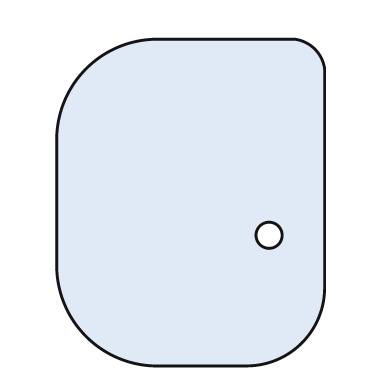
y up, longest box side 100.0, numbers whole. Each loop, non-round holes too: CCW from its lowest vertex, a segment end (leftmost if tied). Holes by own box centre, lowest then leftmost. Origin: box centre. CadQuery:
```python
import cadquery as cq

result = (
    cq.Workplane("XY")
    .moveTo(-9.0, -50.0)
    .lineTo(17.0, -50.0)
    .threePointArc((34.0, -43.0), (41.0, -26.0))
    .lineTo(41.0, 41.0)
    .threePointArc((38.0, 47.0), (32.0, 50.0))
    .lineTo(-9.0, 50.0)
    .threePointArc((-32.0, 41.0), (-41.0, 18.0))
    .lineTo(-41.0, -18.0)
    .threePointArc((-32.0, -41.0), (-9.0, -50.0))
    .close()
    .moveTo(24.0, -10.0)
    .circle(4.0)
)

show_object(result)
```